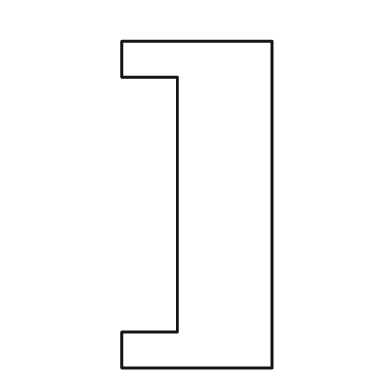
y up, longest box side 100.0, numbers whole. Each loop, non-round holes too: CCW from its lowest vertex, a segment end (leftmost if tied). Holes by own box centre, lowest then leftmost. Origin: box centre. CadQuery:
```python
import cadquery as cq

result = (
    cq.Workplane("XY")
    .moveTo(-23.0, -50.0)
    .lineTo(23.0, -50.0)
    .lineTo(23.0, 50.0)
    .lineTo(-23.0, 50.0)
    .lineTo(-23.0, 39.0)
    .lineTo(-6.0, 39.0)
    .lineTo(-6.0, -39.0)
    .lineTo(-23.0, -39.0)
    .close()
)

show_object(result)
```